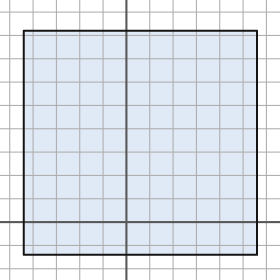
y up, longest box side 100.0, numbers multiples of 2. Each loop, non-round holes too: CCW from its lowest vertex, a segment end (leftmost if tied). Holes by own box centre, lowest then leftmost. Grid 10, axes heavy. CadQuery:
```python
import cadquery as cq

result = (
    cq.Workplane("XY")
    .moveTo(-44.0, -14.0)
    .lineTo(56.0, -14.0)
    .lineTo(56.0, 82.0)
    .lineTo(-44.0, 82.0)
    .close()
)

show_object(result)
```